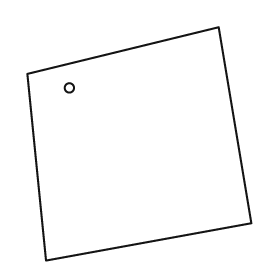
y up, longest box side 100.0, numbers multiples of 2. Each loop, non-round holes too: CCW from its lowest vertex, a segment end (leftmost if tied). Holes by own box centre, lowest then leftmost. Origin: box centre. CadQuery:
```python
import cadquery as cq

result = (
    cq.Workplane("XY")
    .moveTo(-40.0, -50.0)
    .lineTo(48.0, -34.0)
    .lineTo(34.0, 50.0)
    .lineTo(-48.0, 30.0)
    .close()
    .moveTo(-30.0, 24.0)
    .circle(2.0)
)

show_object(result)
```